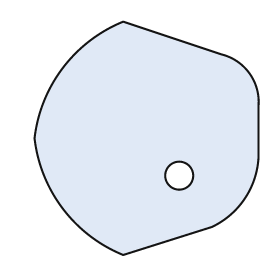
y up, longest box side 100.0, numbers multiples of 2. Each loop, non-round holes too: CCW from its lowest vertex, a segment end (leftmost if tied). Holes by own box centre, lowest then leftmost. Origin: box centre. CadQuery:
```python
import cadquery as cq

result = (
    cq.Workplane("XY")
    .moveTo(-10.0, -50.0)
    .lineTo(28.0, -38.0)
    .threePointArc((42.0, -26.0), (48.0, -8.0))
    .lineTo(48.0, 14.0)
    .threePointArc((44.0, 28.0), (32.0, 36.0))
    .lineTo(-10.0, 50.0)
    .threePointArc((-36.0, 30.0), (-48.0, 0.0))
    .threePointArc((-36.0, -30.0), (-10.0, -50.0))
    .close()
    .moveTo(14.0, -16.0)
    .circle(6.0)
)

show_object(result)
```